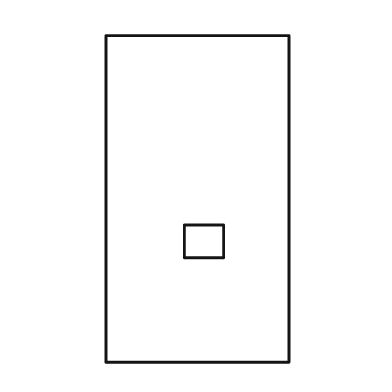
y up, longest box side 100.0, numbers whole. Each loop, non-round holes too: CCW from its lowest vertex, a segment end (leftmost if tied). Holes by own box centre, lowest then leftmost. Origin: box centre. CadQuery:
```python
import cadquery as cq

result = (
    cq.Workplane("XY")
    .moveTo(-28.0, -50.0)
    .lineTo(28.0, -50.0)
    .lineTo(28.0, 50.0)
    .lineTo(-28.0, 50.0)
    .close()
    .moveTo(-4.0, -18.0)
    .lineTo(8.0, -18.0)
    .lineTo(8.0, -8.0)
    .lineTo(-4.0, -8.0)
    .close()
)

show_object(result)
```